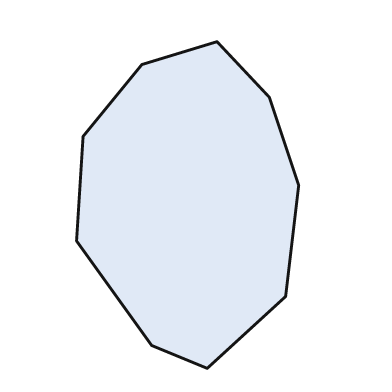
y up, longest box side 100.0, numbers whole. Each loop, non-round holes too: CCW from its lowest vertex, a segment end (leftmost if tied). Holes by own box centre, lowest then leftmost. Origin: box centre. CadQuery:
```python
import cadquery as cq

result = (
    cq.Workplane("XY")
    .moveTo(6.0, -50.0)
    .lineTo(30.0, -28.0)
    .lineTo(34.0, 6.0)
    .lineTo(25.0, 33.0)
    .lineTo(9.0, 50.0)
    .lineTo(-14.0, 43.0)
    .lineTo(-32.0, 21.0)
    .lineTo(-34.0, -11.0)
    .lineTo(-11.0, -43.0)
    .close()
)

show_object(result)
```